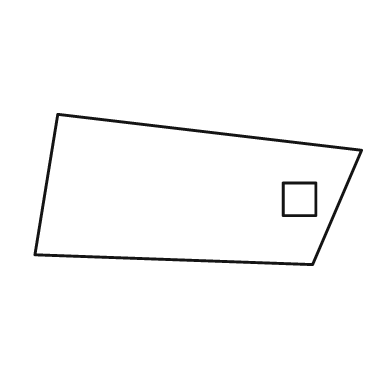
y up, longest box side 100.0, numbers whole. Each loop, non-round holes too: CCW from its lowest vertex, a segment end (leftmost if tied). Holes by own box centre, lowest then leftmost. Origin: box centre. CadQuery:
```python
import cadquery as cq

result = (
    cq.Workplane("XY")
    .moveTo(35.0, -23.0)
    .lineTo(50.0, 12.0)
    .lineTo(-43.0, 23.0)
    .lineTo(-50.0, -20.0)
    .close()
    .moveTo(26.0, -8.0)
    .lineTo(36.0, -8.0)
    .lineTo(36.0, 2.0)
    .lineTo(26.0, 2.0)
    .close()
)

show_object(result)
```